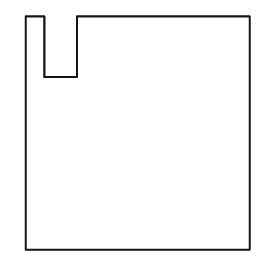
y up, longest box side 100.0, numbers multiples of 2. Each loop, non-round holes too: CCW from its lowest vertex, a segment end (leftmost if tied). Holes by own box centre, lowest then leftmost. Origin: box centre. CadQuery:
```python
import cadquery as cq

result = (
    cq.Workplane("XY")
    .moveTo(-48.0, -50.0)
    .lineTo(48.0, -50.0)
    .lineTo(48.0, 50.0)
    .lineTo(-26.0, 50.0)
    .lineTo(-26.0, 24.0)
    .lineTo(-40.0, 24.0)
    .lineTo(-40.0, 50.0)
    .lineTo(-48.0, 50.0)
    .close()
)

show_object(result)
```